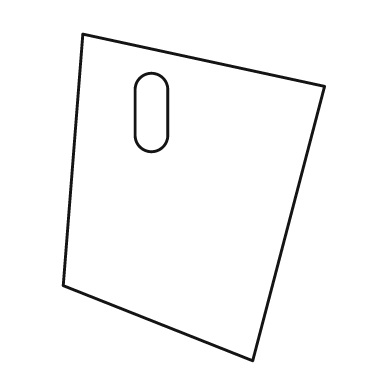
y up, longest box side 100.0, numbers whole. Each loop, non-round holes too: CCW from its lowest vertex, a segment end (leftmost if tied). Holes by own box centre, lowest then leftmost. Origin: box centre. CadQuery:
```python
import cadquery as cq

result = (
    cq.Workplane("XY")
    .moveTo(18.0, -50.0)
    .lineTo(40.0, 34.0)
    .lineTo(-34.0, 50.0)
    .lineTo(-40.0, -27.0)
    .close()
    .moveTo(-18.0, 19.0)
    .threePointArc((-13.0, 14.0), (-8.0, 19.0))
    .lineTo(-8.0, 33.0)
    .threePointArc((-13.0, 38.0), (-18.0, 33.0))
    .close()
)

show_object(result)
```